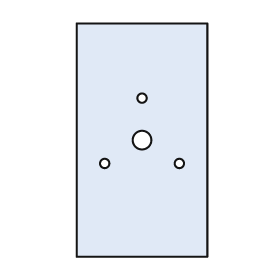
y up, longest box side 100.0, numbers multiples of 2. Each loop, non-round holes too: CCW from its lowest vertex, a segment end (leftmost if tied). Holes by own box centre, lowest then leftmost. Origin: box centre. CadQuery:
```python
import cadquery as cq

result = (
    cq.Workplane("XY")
    .moveTo(-28.0, -50.0)
    .lineTo(28.0, -50.0)
    .lineTo(28.0, 50.0)
    .lineTo(-28.0, 50.0)
    .close()
    .moveTo(-16.0, -10.0)
    .circle(2.0)
    .moveTo(16.0, -10.0)
    .circle(2.0)
    .moveTo(0.0, 0.0)
    .circle(4.0)
    .moveTo(0.0, 18.0)
    .circle(2.0)
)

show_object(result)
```